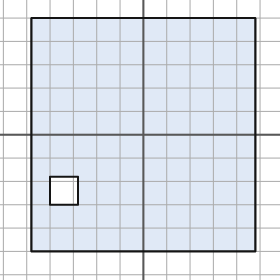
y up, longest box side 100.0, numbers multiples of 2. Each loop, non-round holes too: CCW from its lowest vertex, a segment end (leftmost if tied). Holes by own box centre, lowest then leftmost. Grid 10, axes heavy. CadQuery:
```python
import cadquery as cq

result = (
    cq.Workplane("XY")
    .moveTo(-48.0, -50.0)
    .lineTo(48.0, -50.0)
    .lineTo(48.0, 50.0)
    .lineTo(-48.0, 50.0)
    .close()
    .moveTo(-40.0, -30.0)
    .lineTo(-28.0, -30.0)
    .lineTo(-28.0, -18.0)
    .lineTo(-40.0, -18.0)
    .close()
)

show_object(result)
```